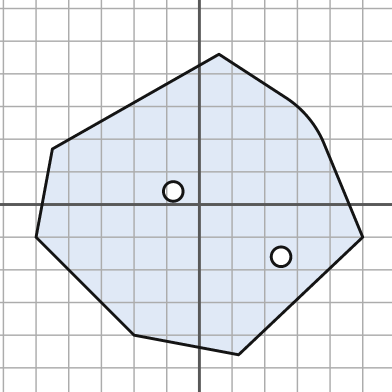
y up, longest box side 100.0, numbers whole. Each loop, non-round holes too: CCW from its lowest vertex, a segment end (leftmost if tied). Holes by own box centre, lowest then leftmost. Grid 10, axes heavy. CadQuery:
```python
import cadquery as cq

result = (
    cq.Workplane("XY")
    .moveTo(12.0, -46.0)
    .lineTo(50.0, -10.0)
    .lineTo(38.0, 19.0)
    .threePointArc((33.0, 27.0), (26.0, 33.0))
    .lineTo(6.0, 46.0)
    .lineTo(-45.0, 17.0)
    .lineTo(-50.0, -10.0)
    .lineTo(-20.0, -40.0)
    .close()
    .moveTo(25.0, -16.0)
    .circle(3.0)
    .moveTo(-8.0, 4.0)
    .circle(3.0)
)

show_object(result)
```